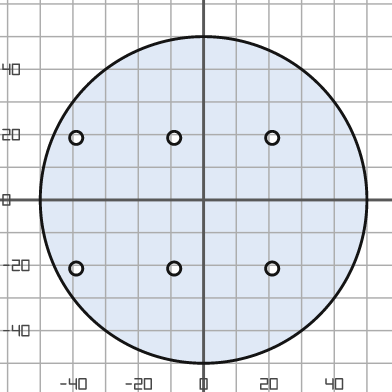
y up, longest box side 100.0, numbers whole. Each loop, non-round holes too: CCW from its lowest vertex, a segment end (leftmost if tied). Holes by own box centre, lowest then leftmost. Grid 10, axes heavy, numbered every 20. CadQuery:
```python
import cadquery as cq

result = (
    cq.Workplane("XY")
    .moveTo(0.0, 0.0)
    .circle(50.0)
    .moveTo(-39.0, -21.0)
    .circle(2.0)
    .moveTo(-9.0, -21.0)
    .circle(2.0)
    .moveTo(21.0, -21.0)
    .circle(2.0)
    .moveTo(-39.0, 19.0)
    .circle(2.0)
    .moveTo(-9.0, 19.0)
    .circle(2.0)
    .moveTo(21.0, 19.0)
    .circle(2.0)
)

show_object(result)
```